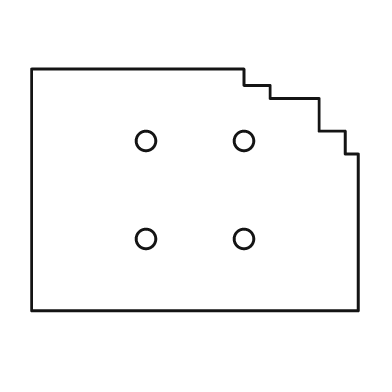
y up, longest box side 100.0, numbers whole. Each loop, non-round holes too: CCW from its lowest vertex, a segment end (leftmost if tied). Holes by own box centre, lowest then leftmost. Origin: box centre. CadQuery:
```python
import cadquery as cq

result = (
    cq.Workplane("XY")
    .moveTo(-50.0, -37.0)
    .lineTo(50.0, -37.0)
    .lineTo(50.0, 11.0)
    .lineTo(46.0, 11.0)
    .lineTo(46.0, 18.0)
    .lineTo(38.0, 18.0)
    .lineTo(38.0, 28.0)
    .lineTo(23.0, 28.0)
    .lineTo(23.0, 32.0)
    .lineTo(15.0, 32.0)
    .lineTo(15.0, 37.0)
    .lineTo(-50.0, 37.0)
    .close()
    .moveTo(-15.0, -15.0)
    .circle(3.0)
    .moveTo(15.0, -15.0)
    .circle(3.0)
    .moveTo(-15.0, 15.0)
    .circle(3.0)
    .moveTo(15.0, 15.0)
    .circle(3.0)
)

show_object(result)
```